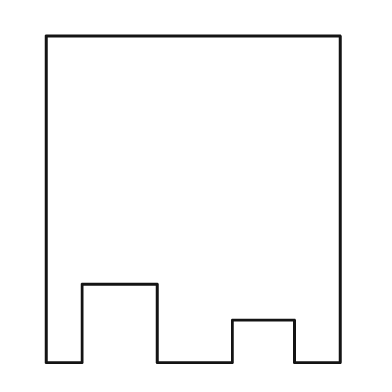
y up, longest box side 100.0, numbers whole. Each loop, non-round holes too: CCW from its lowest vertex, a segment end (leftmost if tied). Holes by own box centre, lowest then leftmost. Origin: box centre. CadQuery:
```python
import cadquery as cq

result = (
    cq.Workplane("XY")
    .moveTo(-45.0, -50.0)
    .lineTo(-34.0, -50.0)
    .lineTo(-34.0, -26.0)
    .lineTo(-11.0, -26.0)
    .lineTo(-11.0, -50.0)
    .lineTo(12.0, -50.0)
    .lineTo(12.0, -37.0)
    .lineTo(31.0, -37.0)
    .lineTo(31.0, -50.0)
    .lineTo(45.0, -50.0)
    .lineTo(45.0, 50.0)
    .lineTo(-45.0, 50.0)
    .close()
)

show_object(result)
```